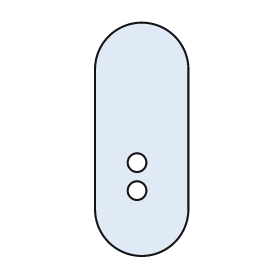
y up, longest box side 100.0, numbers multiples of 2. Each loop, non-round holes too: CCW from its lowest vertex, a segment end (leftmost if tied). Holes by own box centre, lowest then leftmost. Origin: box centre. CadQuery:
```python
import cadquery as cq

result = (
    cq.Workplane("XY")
    .moveTo(-20.0, -30.0)
    .threePointArc((0.0, -50.0), (20.0, -30.0))
    .lineTo(20.0, 30.0)
    .threePointArc((0.0, 50.0), (-20.0, 30.0))
    .close()
    .moveTo(-2.0, -22.0)
    .circle(4.0)
    .moveTo(-2.0, -10.0)
    .circle(4.0)
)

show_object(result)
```